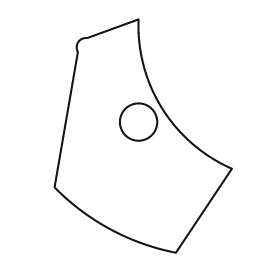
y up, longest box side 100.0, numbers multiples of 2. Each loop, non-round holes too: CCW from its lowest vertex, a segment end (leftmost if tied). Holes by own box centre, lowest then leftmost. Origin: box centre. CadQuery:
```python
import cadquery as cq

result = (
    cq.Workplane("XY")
    .moveTo(14.0, -50.0)
    .lineTo(38.0, -14.0)
    .threePointArc((8.0, 12.0), (-2.0, 50.0))
    .lineTo(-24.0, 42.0)
    .threePointArc((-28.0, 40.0), (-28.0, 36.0))
    .lineTo(-38.0, -22.0)
    .threePointArc((-14.0, -40.0), (14.0, -50.0))
    .close()
    .moveTo(-2.0, 6.0)
    .circle(8.0)
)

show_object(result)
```